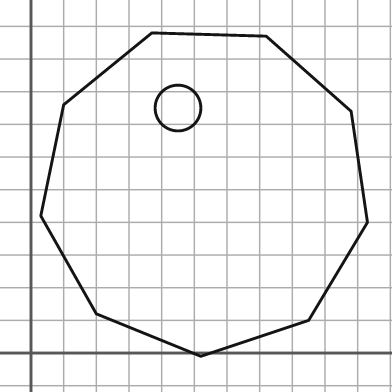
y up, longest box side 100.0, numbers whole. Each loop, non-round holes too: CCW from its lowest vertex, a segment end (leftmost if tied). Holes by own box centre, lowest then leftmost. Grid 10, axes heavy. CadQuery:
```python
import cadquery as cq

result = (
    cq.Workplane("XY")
    .moveTo(52.0, -1.0)
    .lineTo(85.0, 10.0)
    .lineTo(103.0, 40.0)
    .lineTo(98.0, 74.0)
    .lineTo(72.0, 97.0)
    .lineTo(37.0, 98.0)
    .lineTo(10.0, 76.0)
    .lineTo(3.0, 42.0)
    .lineTo(20.0, 12.0)
    .close()
    .moveTo(45.0, 75.0)
    .circle(7.0)
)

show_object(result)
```